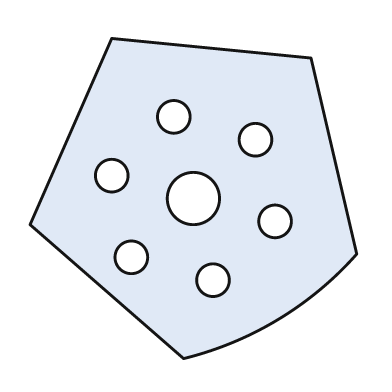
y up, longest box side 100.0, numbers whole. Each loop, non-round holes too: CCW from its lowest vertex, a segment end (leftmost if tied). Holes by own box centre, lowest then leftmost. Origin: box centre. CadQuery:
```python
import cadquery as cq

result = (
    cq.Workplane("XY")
    .moveTo(-3.0, -49.0)
    .threePointArc((26.0, -37.0), (50.0, -17.0))
    .lineTo(36.0, 43.0)
    .lineTo(-25.0, 49.0)
    .lineTo(-50.0, -8.0)
    .close()
    .moveTo(6.0, -25.0)
    .circle(5.0)
    .moveTo(-19.0, -18.0)
    .circle(5.0)
    .moveTo(25.0, -7.0)
    .circle(5.0)
    .moveTo(0.0, 0.0)
    .circle(8.0)
    .moveTo(-25.0, 7.0)
    .circle(5.0)
    .moveTo(19.0, 18.0)
    .circle(5.0)
    .moveTo(-6.0, 25.0)
    .circle(5.0)
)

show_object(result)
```